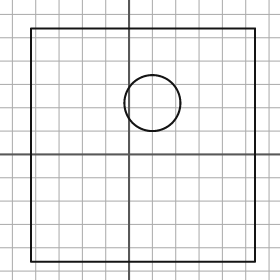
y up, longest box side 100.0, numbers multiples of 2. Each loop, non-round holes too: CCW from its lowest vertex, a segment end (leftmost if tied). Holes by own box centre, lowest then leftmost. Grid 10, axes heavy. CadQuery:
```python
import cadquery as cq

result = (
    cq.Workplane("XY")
    .moveTo(-42.0, -46.0)
    .lineTo(54.0, -46.0)
    .lineTo(54.0, 54.0)
    .lineTo(-42.0, 54.0)
    .close()
    .moveTo(10.0, 22.0)
    .circle(12.0)
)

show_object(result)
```